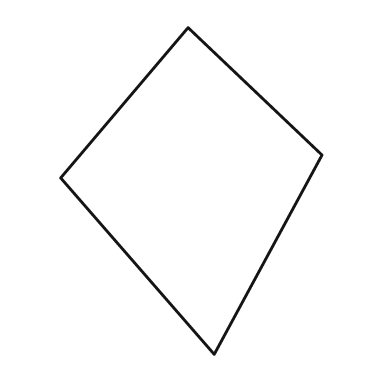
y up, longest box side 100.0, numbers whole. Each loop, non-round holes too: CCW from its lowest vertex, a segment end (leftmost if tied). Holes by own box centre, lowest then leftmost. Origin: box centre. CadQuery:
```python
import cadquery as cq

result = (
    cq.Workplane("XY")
    .moveTo(7.0, -50.0)
    .lineTo(40.0, 11.0)
    .lineTo(-1.0, 50.0)
    .lineTo(-40.0, 4.0)
    .close()
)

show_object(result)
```